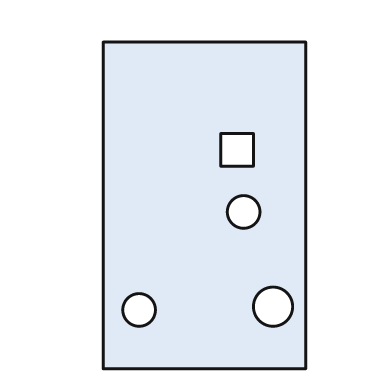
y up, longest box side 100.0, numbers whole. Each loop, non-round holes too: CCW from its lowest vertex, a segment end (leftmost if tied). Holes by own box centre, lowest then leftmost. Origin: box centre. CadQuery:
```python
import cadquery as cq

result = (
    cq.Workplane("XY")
    .moveTo(-31.0, -50.0)
    .lineTo(31.0, -50.0)
    .lineTo(31.0, 50.0)
    .lineTo(-31.0, 50.0)
    .close()
    .moveTo(-20.0, -32.0)
    .circle(5.0)
    .moveTo(21.0, -31.0)
    .circle(6.0)
    .moveTo(12.0, -2.0)
    .circle(5.0)
    .moveTo(5.0, 12.0)
    .lineTo(15.0, 12.0)
    .lineTo(15.0, 22.0)
    .lineTo(5.0, 22.0)
    .close()
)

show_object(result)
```